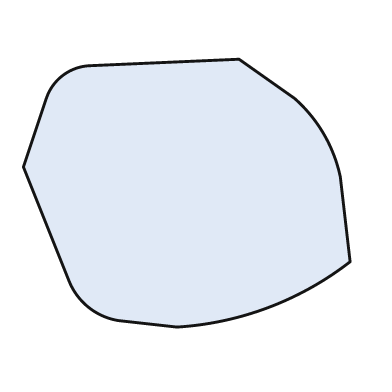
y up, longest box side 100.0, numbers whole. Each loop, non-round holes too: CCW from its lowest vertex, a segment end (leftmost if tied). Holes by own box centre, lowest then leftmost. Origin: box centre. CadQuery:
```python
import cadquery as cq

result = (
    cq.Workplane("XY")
    .moveTo(-3.0, -41.0)
    .threePointArc((25.0, -35.0), (50.0, -21.0))
    .lineTo(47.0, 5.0)
    .threePointArc((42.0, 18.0), (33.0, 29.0))
    .lineTo(16.0, 41.0)
    .lineTo(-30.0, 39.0)
    .threePointArc((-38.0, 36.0), (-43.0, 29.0))
    .lineTo(-50.0, 8.0)
    .lineTo(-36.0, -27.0)
    .threePointArc((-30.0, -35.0), (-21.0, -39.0))
    .close()
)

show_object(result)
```